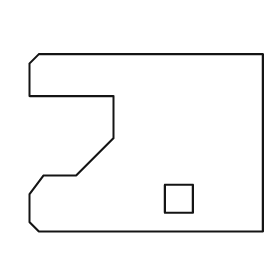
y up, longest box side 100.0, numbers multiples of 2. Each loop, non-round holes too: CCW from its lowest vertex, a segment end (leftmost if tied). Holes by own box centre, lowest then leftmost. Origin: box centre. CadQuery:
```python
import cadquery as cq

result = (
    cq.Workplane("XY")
    .moveTo(-46.0, -38.0)
    .lineTo(50.0, -38.0)
    .lineTo(50.0, 38.0)
    .lineTo(-46.0, 38.0)
    .lineTo(-50.0, 34.0)
    .lineTo(-50.0, 20.0)
    .lineTo(-14.0, 20.0)
    .lineTo(-14.0, 2.0)
    .lineTo(-30.0, -14.0)
    .lineTo(-44.0, -14.0)
    .lineTo(-50.0, -22.0)
    .lineTo(-50.0, -34.0)
    .close()
    .moveTo(8.0, -30.0)
    .lineTo(20.0, -30.0)
    .lineTo(20.0, -18.0)
    .lineTo(8.0, -18.0)
    .close()
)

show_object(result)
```